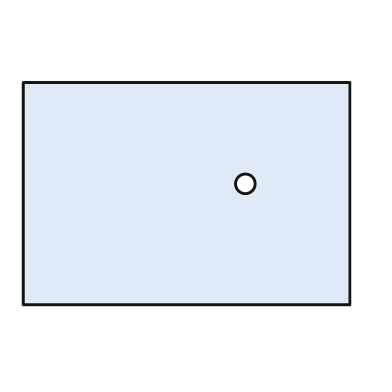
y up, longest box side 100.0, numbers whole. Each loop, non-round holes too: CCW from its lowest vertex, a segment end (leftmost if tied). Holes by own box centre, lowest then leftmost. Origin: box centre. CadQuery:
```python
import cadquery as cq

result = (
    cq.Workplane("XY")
    .moveTo(-50.0, -34.0)
    .lineTo(50.0, -34.0)
    .lineTo(50.0, 34.0)
    .lineTo(-50.0, 34.0)
    .close()
    .moveTo(18.0, 3.0)
    .circle(3.0)
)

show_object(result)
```